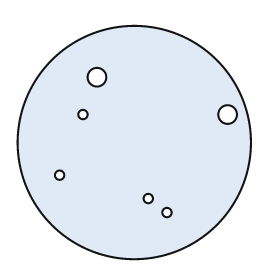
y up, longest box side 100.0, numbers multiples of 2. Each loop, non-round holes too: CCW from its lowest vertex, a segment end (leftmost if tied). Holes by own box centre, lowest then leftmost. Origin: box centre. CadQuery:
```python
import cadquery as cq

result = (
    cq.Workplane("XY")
    .moveTo(0.0, 0.0)
    .circle(50.0)
    .moveTo(14.0, -30.0)
    .circle(2.0)
    .moveTo(6.0, -24.0)
    .circle(2.0)
    .moveTo(-32.0, -14.0)
    .circle(2.0)
    .moveTo(-22.0, 12.0)
    .circle(2.0)
    .moveTo(40.0, 12.0)
    .circle(4.0)
    .moveTo(-16.0, 28.0)
    .circle(4.0)
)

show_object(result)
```